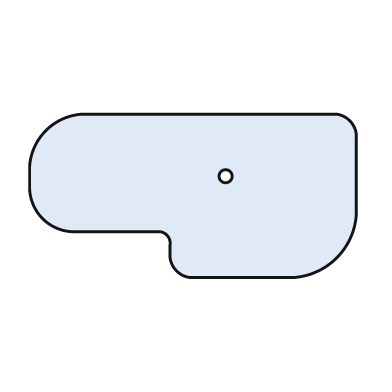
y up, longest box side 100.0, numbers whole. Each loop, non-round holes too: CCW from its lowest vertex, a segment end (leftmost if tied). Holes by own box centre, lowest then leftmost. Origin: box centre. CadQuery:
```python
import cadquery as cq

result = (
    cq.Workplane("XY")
    .moveTo(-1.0, -25.0)
    .lineTo(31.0, -25.0)
    .threePointArc((44.0, -19.0), (50.0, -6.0))
    .lineTo(50.0, 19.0)
    .threePointArc((48.0, 23.0), (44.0, 25.0))
    .lineTo(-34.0, 25.0)
    .threePointArc((-45.0, 20.0), (-50.0, 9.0))
    .lineTo(-50.0, 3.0)
    .threePointArc((-46.0, -7.0), (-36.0, -11.0))
    .lineTo(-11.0, -11.0)
    .threePointArc((-8.0, -12.0), (-7.0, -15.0))
    .lineTo(-7.0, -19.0)
    .threePointArc((-5.0, -23.0), (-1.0, -25.0))
    .close()
    .moveTo(10.0, 6.0)
    .circle(2.0)
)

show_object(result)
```